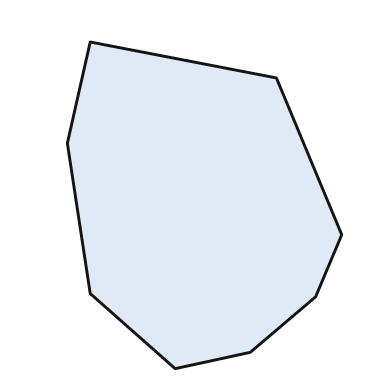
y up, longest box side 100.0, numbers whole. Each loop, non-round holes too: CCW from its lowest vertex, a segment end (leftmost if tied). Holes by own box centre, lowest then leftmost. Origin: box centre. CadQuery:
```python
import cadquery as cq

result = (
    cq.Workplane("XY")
    .moveTo(-9.0, -50.0)
    .lineTo(14.0, -45.0)
    .lineTo(34.0, -28.0)
    .lineTo(42.0, -9.0)
    .lineTo(22.0, 39.0)
    .lineTo(-35.0, 50.0)
    .lineTo(-42.0, 19.0)
    .lineTo(-35.0, -27.0)
    .close()
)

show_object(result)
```